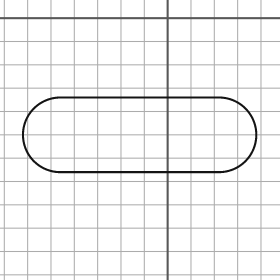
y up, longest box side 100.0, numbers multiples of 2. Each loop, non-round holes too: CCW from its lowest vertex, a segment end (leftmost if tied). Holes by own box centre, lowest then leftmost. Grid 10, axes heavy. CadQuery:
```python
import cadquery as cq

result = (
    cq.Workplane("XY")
    .moveTo(-46.0, -66.0)
    .lineTo(22.0, -66.0)
    .threePointArc((38.0, -50.0), (22.0, -34.0))
    .lineTo(-46.0, -34.0)
    .threePointArc((-62.0, -50.0), (-46.0, -66.0))
    .close()
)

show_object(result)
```